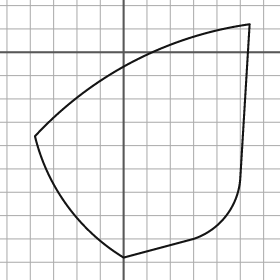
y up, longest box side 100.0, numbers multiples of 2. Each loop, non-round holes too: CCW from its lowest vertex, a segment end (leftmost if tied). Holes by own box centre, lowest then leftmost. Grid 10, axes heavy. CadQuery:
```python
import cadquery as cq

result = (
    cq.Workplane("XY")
    .moveTo(0.0, -88.0)
    .lineTo(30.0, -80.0)
    .threePointArc((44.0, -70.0), (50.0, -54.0))
    .lineTo(54.0, 12.0)
    .threePointArc((4.0, -4.0), (-38.0, -36.0))
    .threePointArc((-24.0, -66.0), (0.0, -88.0))
    .close()
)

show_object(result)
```